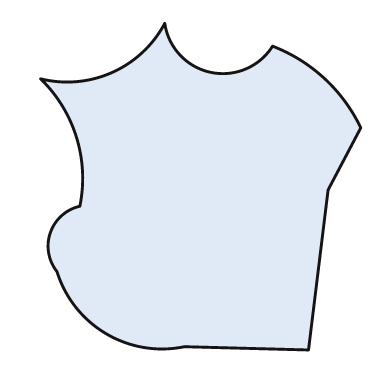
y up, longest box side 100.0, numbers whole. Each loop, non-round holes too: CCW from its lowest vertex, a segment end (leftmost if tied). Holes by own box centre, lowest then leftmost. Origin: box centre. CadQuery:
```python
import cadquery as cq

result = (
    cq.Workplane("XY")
    .moveTo(33.0, -50.0)
    .lineTo(39.0, -1.0)
    .lineTo(49.0, 18.0)
    .threePointArc((38.0, 33.0), (22.0, 43.0))
    .threePointArc((3.0, 35.0), (-11.0, 50.0))
    .threePointArc((-27.0, 35.0), (-49.0, 33.0))
    .threePointArc((-38.0, 15.0), (-37.0, -6.0))
    .threePointArc((-46.0, -14.0), (-44.0, -26.0))
    .threePointArc((-29.0, -45.0), (-5.0, -49.0))
    .close()
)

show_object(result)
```